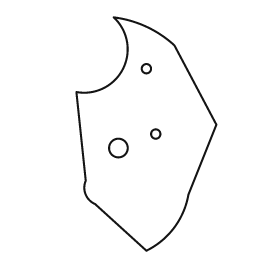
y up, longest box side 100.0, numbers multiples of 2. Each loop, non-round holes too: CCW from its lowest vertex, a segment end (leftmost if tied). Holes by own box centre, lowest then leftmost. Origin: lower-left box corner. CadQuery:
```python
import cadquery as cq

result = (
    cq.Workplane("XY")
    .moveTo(30.0, 0.0)
    .threePointArc((42.0, 10.0), (48.0, 24.0))
    .lineTo(60.0, 54.0)
    .lineTo(42.0, 88.0)
    .threePointArc((30.0, 96.0), (16.0, 100.0))
    .threePointArc((20.0, 78.0), (0.0, 68.0))
    .lineTo(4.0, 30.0)
    .threePointArc((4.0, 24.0), (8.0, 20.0))
    .close()
    .moveTo(18.0, 44.0)
    .circle(4.0)
    .moveTo(34.0, 50.0)
    .circle(2.0)
    .moveTo(30.0, 78.0)
    .circle(2.0)
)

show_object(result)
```